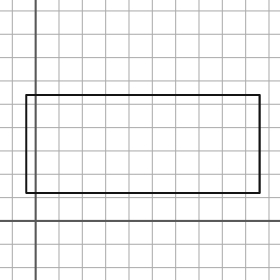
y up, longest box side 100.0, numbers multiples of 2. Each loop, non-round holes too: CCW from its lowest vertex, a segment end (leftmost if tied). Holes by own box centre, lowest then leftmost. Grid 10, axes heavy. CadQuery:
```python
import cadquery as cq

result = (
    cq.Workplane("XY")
    .moveTo(-4.0, 12.0)
    .lineTo(96.0, 12.0)
    .lineTo(96.0, 54.0)
    .lineTo(-4.0, 54.0)
    .close()
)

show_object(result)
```